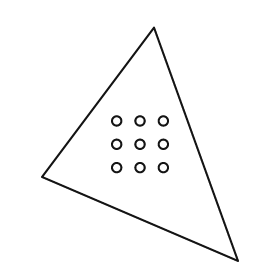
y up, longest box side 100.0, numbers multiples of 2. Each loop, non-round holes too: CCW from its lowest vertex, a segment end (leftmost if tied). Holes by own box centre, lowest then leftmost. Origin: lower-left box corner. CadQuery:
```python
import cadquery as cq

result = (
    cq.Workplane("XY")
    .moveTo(84.0, 0.0)
    .lineTo(48.0, 100.0)
    .lineTo(0.0, 36.0)
    .close()
    .moveTo(32.0, 40.0)
    .circle(2.0)
    .moveTo(42.0, 40.0)
    .circle(2.0)
    .moveTo(52.0, 40.0)
    .circle(2.0)
    .moveTo(32.0, 50.0)
    .circle(2.0)
    .moveTo(42.0, 50.0)
    .circle(2.0)
    .moveTo(52.0, 50.0)
    .circle(2.0)
    .moveTo(32.0, 60.0)
    .circle(2.0)
    .moveTo(42.0, 60.0)
    .circle(2.0)
    .moveTo(52.0, 60.0)
    .circle(2.0)
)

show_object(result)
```